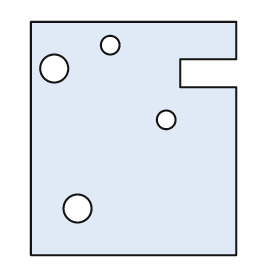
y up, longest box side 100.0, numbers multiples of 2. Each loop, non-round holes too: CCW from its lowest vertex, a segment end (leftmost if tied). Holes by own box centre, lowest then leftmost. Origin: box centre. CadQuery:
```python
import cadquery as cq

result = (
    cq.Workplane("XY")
    .moveTo(-44.0, -50.0)
    .lineTo(44.0, -50.0)
    .lineTo(44.0, 22.0)
    .lineTo(20.0, 22.0)
    .lineTo(20.0, 34.0)
    .lineTo(44.0, 34.0)
    .lineTo(44.0, 50.0)
    .lineTo(-44.0, 50.0)
    .close()
    .moveTo(-24.0, -30.0)
    .circle(6.0)
    .moveTo(14.0, 8.0)
    .circle(4.0)
    .moveTo(-34.0, 30.0)
    .circle(6.0)
    .moveTo(-10.0, 40.0)
    .circle(4.0)
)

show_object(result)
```